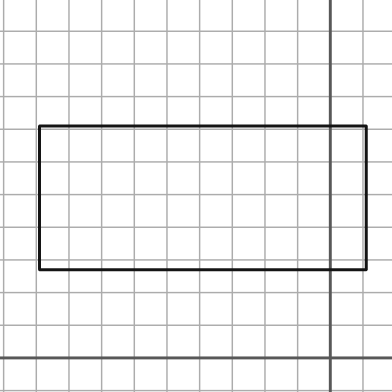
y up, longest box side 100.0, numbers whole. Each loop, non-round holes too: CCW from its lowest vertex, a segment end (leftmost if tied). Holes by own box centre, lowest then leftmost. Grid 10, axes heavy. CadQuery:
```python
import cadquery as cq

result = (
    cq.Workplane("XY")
    .moveTo(-89.0, 27.0)
    .lineTo(11.0, 27.0)
    .lineTo(11.0, 71.0)
    .lineTo(-89.0, 71.0)
    .close()
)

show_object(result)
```